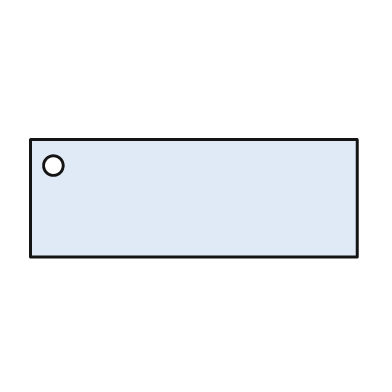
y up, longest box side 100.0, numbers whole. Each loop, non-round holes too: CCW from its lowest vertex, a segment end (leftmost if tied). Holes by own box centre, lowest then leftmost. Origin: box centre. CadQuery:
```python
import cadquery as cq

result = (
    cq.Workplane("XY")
    .moveTo(-50.0, -18.0)
    .lineTo(50.0, -18.0)
    .lineTo(50.0, 18.0)
    .lineTo(-50.0, 18.0)
    .close()
    .moveTo(-43.0, 10.0)
    .circle(3.0)
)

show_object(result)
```